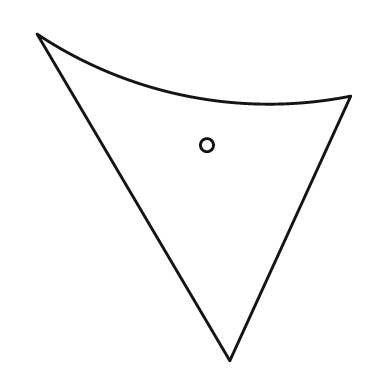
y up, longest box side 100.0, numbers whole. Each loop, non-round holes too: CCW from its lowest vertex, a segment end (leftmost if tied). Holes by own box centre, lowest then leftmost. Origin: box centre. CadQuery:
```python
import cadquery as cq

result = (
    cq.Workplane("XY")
    .moveTo(11.0, -50.0)
    .lineTo(48.0, 31.0)
    .threePointArc((-2.0, 31.0), (-48.0, 50.0))
    .close()
    .moveTo(4.0, 16.0)
    .circle(2.0)
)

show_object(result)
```